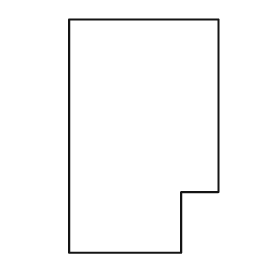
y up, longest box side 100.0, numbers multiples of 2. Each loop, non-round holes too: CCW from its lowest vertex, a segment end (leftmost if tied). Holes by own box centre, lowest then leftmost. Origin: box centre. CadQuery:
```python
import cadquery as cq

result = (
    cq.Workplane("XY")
    .moveTo(-32.0, -50.0)
    .lineTo(16.0, -50.0)
    .lineTo(16.0, -24.0)
    .lineTo(32.0, -24.0)
    .lineTo(32.0, 50.0)
    .lineTo(-32.0, 50.0)
    .close()
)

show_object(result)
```